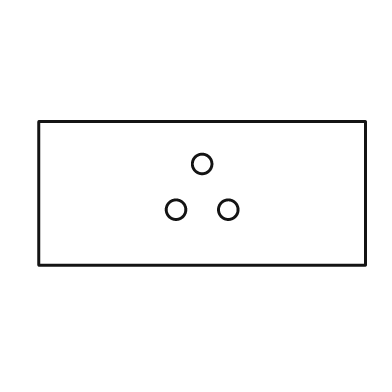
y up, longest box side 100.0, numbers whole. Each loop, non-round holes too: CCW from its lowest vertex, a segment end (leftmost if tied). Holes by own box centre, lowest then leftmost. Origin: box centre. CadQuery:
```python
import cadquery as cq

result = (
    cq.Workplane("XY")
    .moveTo(-50.0, -22.0)
    .lineTo(50.0, -22.0)
    .lineTo(50.0, 22.0)
    .lineTo(-50.0, 22.0)
    .close()
    .moveTo(-8.0, -5.0)
    .circle(3.0)
    .moveTo(8.0, -5.0)
    .circle(3.0)
    .moveTo(0.0, 9.0)
    .circle(3.0)
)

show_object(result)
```